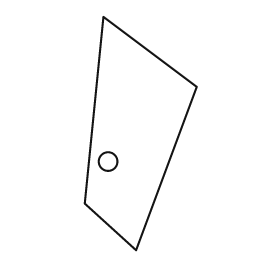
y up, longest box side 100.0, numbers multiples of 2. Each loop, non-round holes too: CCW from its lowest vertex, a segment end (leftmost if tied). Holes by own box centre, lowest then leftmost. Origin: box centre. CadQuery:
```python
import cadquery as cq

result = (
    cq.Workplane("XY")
    .moveTo(-2.0, -50.0)
    .lineTo(24.0, 20.0)
    .lineTo(-16.0, 50.0)
    .lineTo(-24.0, -30.0)
    .close()
    .moveTo(-14.0, -12.0)
    .circle(4.0)
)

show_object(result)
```